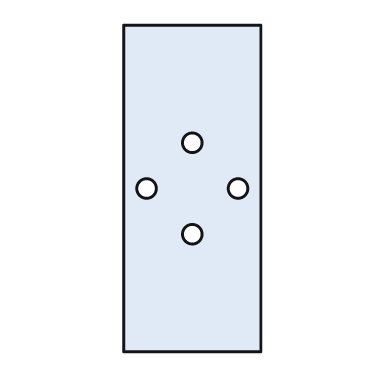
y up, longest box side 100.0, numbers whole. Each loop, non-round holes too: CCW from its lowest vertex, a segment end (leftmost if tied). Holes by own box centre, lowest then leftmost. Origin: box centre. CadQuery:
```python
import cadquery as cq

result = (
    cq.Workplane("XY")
    .moveTo(-21.0, -50.0)
    .lineTo(21.0, -50.0)
    .lineTo(21.0, 50.0)
    .lineTo(-21.0, 50.0)
    .close()
    .moveTo(0.0, -14.0)
    .circle(3.0)
    .moveTo(-14.0, 0.0)
    .circle(3.0)
    .moveTo(14.0, 0.0)
    .circle(3.0)
    .moveTo(0.0, 14.0)
    .circle(3.0)
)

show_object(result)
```